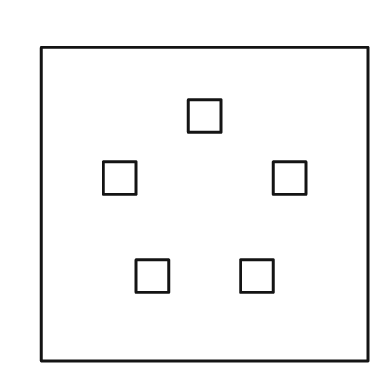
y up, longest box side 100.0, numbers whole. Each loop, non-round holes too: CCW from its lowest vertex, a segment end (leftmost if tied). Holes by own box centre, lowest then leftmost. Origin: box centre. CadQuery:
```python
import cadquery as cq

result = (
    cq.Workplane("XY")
    .moveTo(-50.0, -48.0)
    .lineTo(50.0, -48.0)
    .lineTo(50.0, 48.0)
    .lineTo(-50.0, 48.0)
    .close()
    .moveTo(-21.0, -27.0)
    .lineTo(-11.0, -27.0)
    .lineTo(-11.0, -17.0)
    .lineTo(-21.0, -17.0)
    .close()
    .moveTo(11.0, -27.0)
    .lineTo(21.0, -27.0)
    .lineTo(21.0, -17.0)
    .lineTo(11.0, -17.0)
    .close()
    .moveTo(-31.0, 3.0)
    .lineTo(-21.0, 3.0)
    .lineTo(-21.0, 13.0)
    .lineTo(-31.0, 13.0)
    .close()
    .moveTo(21.0, 3.0)
    .lineTo(31.0, 3.0)
    .lineTo(31.0, 13.0)
    .lineTo(21.0, 13.0)
    .close()
    .moveTo(-5.0, 22.0)
    .lineTo(5.0, 22.0)
    .lineTo(5.0, 32.0)
    .lineTo(-5.0, 32.0)
    .close()
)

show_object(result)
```